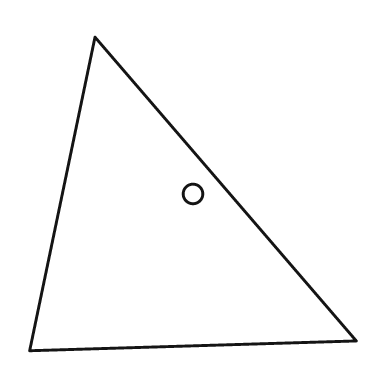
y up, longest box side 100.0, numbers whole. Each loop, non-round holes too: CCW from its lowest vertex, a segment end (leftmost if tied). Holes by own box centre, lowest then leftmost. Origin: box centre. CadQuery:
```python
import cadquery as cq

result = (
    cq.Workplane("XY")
    .moveTo(-50.0, -48.0)
    .lineTo(50.0, -45.0)
    .lineTo(-30.0, 48.0)
    .close()
    .moveTo(0.0, 0.0)
    .circle(3.0)
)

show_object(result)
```